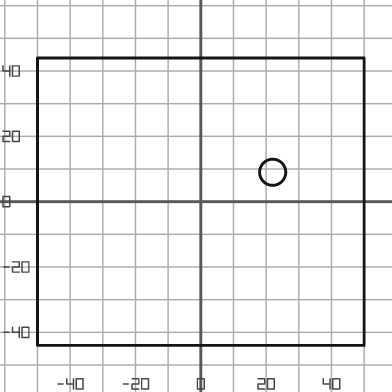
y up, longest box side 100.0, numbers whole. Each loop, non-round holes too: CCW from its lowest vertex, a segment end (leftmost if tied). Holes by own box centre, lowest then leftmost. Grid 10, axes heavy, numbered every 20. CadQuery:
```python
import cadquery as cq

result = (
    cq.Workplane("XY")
    .moveTo(-50.0, -44.0)
    .lineTo(50.0, -44.0)
    .lineTo(50.0, 44.0)
    .lineTo(-50.0, 44.0)
    .close()
    .moveTo(22.0, 9.0)
    .circle(4.0)
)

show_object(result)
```